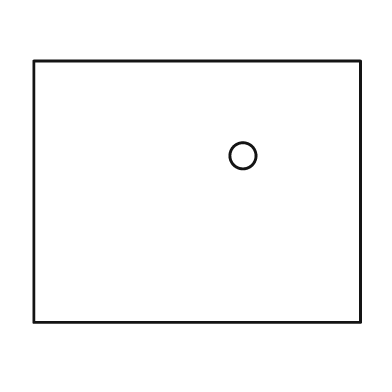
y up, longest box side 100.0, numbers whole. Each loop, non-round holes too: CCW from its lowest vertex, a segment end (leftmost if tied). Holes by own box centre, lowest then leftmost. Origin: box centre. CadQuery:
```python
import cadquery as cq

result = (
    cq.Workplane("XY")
    .moveTo(-50.0, -40.0)
    .lineTo(50.0, -40.0)
    .lineTo(50.0, 40.0)
    .lineTo(-50.0, 40.0)
    .close()
    .moveTo(14.0, 11.0)
    .circle(4.0)
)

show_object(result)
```